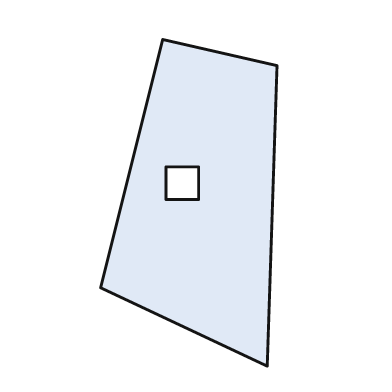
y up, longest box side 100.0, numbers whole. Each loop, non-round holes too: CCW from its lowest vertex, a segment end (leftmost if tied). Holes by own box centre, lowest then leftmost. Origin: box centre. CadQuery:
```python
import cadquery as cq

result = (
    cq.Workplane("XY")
    .moveTo(24.0, -50.0)
    .lineTo(27.0, 42.0)
    .lineTo(-8.0, 50.0)
    .lineTo(-27.0, -26.0)
    .close()
    .moveTo(-7.0, 1.0)
    .lineTo(3.0, 1.0)
    .lineTo(3.0, 11.0)
    .lineTo(-7.0, 11.0)
    .close()
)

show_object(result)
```